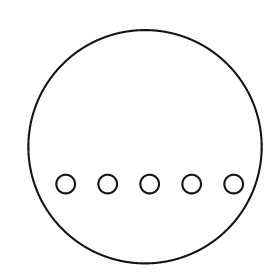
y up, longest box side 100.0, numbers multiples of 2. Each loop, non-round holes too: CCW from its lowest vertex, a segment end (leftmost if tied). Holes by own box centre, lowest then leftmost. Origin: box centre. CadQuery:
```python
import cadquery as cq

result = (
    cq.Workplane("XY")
    .moveTo(0.0, 0.0)
    .circle(50.0)
    .moveTo(-34.0, -16.0)
    .circle(4.0)
    .moveTo(-16.0, -16.0)
    .circle(4.0)
    .moveTo(2.0, -16.0)
    .circle(4.0)
    .moveTo(20.0, -16.0)
    .circle(4.0)
    .moveTo(38.0, -16.0)
    .circle(4.0)
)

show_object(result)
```